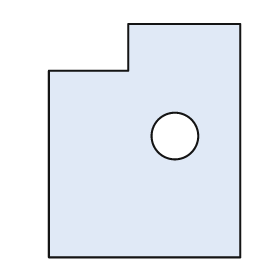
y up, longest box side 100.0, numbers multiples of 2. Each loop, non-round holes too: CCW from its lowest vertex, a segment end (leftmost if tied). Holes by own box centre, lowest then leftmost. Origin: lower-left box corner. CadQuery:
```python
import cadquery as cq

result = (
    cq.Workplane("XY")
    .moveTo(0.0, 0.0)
    .lineTo(82.0, 0.0)
    .lineTo(82.0, 100.0)
    .lineTo(34.0, 100.0)
    .lineTo(34.0, 80.0)
    .lineTo(0.0, 80.0)
    .close()
    .moveTo(54.0, 52.0)
    .circle(10.0)
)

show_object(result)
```